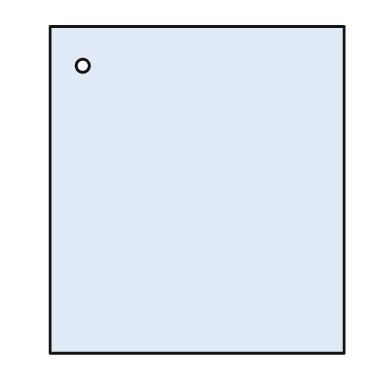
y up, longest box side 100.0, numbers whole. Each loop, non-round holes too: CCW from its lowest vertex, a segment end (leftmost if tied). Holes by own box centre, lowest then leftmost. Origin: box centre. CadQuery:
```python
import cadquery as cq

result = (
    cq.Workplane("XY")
    .moveTo(-45.0, -50.0)
    .lineTo(45.0, -50.0)
    .lineTo(45.0, 50.0)
    .lineTo(-45.0, 50.0)
    .close()
    .moveTo(-35.0, 38.0)
    .circle(2.0)
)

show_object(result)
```